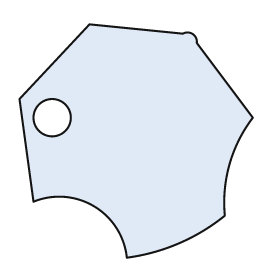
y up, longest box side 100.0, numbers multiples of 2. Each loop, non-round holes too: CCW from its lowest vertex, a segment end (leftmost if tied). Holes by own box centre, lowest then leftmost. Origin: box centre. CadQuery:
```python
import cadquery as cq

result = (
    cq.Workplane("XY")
    .moveTo(-4.0, -50.0)
    .threePointArc((18.0, -44.0), (38.0, -32.0))
    .threePointArc((40.0, -10.0), (50.0, 10.0))
    .lineTo(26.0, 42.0)
    .threePointArc((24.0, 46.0), (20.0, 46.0))
    .lineTo(-20.0, 50.0)
    .lineTo(-50.0, 18.0)
    .lineTo(-44.0, -26.0)
    .threePointArc((-18.0, -28.0), (-4.0, -50.0))
    .close()
    .moveTo(-36.0, 10.0)
    .circle(8.0)
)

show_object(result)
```